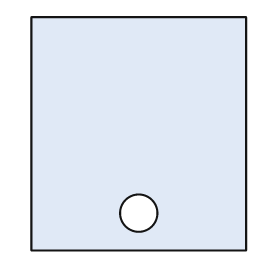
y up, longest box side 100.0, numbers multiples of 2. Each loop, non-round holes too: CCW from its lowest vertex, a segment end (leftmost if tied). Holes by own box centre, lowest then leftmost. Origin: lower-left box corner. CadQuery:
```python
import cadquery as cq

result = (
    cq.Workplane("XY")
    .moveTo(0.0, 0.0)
    .lineTo(92.0, 0.0)
    .lineTo(92.0, 100.0)
    .lineTo(0.0, 100.0)
    .close()
    .moveTo(46.0, 16.0)
    .circle(8.0)
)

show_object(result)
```